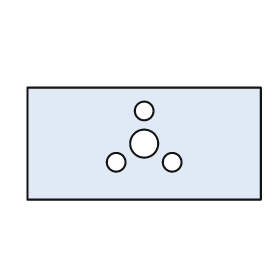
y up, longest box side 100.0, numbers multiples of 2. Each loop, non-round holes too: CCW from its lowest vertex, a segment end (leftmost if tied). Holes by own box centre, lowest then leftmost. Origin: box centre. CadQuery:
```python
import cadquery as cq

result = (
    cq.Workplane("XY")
    .moveTo(-50.0, -24.0)
    .lineTo(50.0, -24.0)
    .lineTo(50.0, 24.0)
    .lineTo(-50.0, 24.0)
    .close()
    .moveTo(-12.0, -8.0)
    .circle(4.0)
    .moveTo(12.0, -8.0)
    .circle(4.0)
    .moveTo(0.0, 0.0)
    .circle(6.0)
    .moveTo(0.0, 14.0)
    .circle(4.0)
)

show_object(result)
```